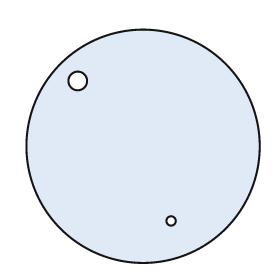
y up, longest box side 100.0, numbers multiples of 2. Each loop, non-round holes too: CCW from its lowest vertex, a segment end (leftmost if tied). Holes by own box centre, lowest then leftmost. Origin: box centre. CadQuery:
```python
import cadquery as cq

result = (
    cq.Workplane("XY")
    .moveTo(0.0, 0.0)
    .circle(50.0)
    .moveTo(12.0, -32.0)
    .circle(2.0)
    .moveTo(-28.0, 28.0)
    .circle(4.0)
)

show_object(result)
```